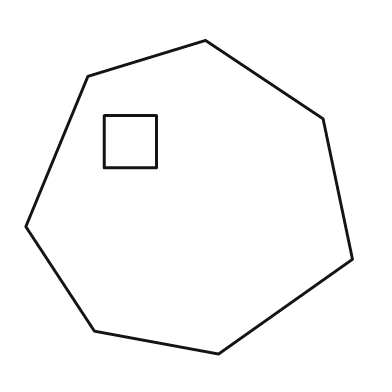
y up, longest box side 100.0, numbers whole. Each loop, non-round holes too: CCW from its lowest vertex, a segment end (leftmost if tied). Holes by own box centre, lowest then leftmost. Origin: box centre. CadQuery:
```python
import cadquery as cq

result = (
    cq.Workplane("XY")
    .moveTo(9.0, -48.0)
    .lineTo(50.0, -19.0)
    .lineTo(41.0, 24.0)
    .lineTo(5.0, 48.0)
    .lineTo(-31.0, 37.0)
    .lineTo(-50.0, -9.0)
    .lineTo(-29.0, -41.0)
    .close()
    .moveTo(-26.0, 9.0)
    .lineTo(-10.0, 9.0)
    .lineTo(-10.0, 25.0)
    .lineTo(-26.0, 25.0)
    .close()
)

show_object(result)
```